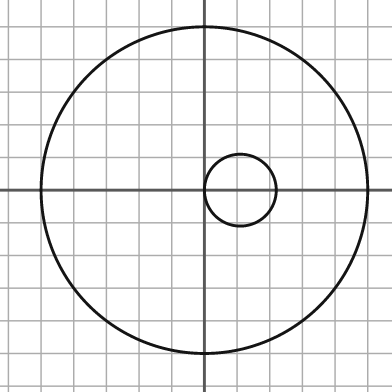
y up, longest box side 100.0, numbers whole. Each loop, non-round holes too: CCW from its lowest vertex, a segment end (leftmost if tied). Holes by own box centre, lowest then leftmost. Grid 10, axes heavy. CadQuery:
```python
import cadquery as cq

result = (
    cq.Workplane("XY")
    .moveTo(0.0, 0.0)
    .circle(50.0)
    .moveTo(11.0, 0.0)
    .circle(11.0)
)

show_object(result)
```